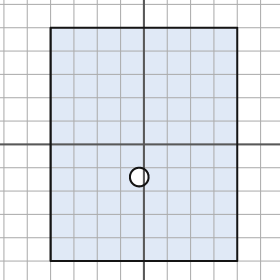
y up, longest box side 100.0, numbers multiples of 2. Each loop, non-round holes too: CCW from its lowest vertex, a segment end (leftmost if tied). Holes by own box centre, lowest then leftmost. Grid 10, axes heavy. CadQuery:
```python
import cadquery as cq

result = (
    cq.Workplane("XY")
    .moveTo(-40.0, -50.0)
    .lineTo(40.0, -50.0)
    .lineTo(40.0, 50.0)
    .lineTo(-40.0, 50.0)
    .close()
    .moveTo(-2.0, -14.0)
    .circle(4.0)
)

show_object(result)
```